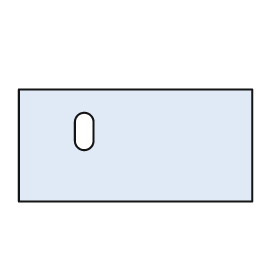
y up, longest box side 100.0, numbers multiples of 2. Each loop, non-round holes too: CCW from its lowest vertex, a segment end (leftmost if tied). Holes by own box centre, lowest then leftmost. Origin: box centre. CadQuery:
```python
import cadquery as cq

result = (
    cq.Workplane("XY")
    .moveTo(-50.0, -24.0)
    .lineTo(50.0, -24.0)
    .lineTo(50.0, 24.0)
    .lineTo(-50.0, 24.0)
    .close()
    .moveTo(-26.0, 2.0)
    .threePointArc((-22.0, -2.0), (-18.0, 2.0))
    .lineTo(-18.0, 10.0)
    .threePointArc((-22.0, 14.0), (-26.0, 10.0))
    .close()
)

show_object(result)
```